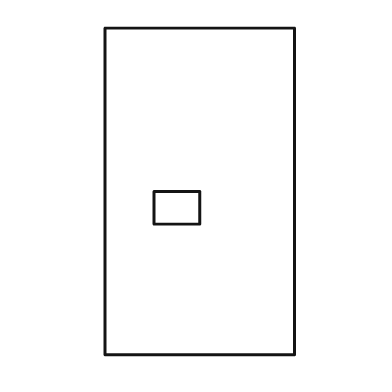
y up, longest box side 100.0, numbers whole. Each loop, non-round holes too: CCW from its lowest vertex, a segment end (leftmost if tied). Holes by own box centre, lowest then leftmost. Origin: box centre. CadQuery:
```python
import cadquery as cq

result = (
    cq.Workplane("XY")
    .moveTo(-29.0, -50.0)
    .lineTo(29.0, -50.0)
    .lineTo(29.0, 50.0)
    .lineTo(-29.0, 50.0)
    .close()
    .moveTo(-14.0, -10.0)
    .lineTo(0.0, -10.0)
    .lineTo(0.0, 0.0)
    .lineTo(-14.0, 0.0)
    .close()
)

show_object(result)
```